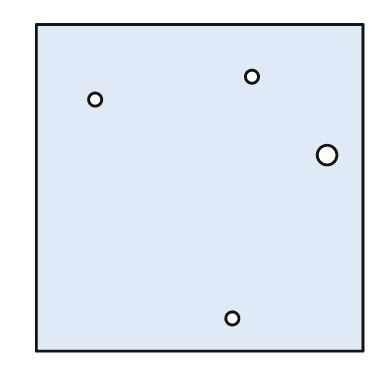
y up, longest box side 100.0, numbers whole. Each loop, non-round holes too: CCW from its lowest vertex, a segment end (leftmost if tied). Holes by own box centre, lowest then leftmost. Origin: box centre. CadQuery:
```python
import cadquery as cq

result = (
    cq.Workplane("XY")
    .moveTo(-50.0, -50.0)
    .lineTo(50.0, -50.0)
    .lineTo(50.0, 50.0)
    .lineTo(-50.0, 50.0)
    .close()
    .moveTo(10.0, -40.0)
    .circle(2.0)
    .moveTo(39.0, 10.0)
    .circle(3.0)
    .moveTo(-32.0, 27.0)
    .circle(2.0)
    .moveTo(16.0, 34.0)
    .circle(2.0)
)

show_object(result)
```